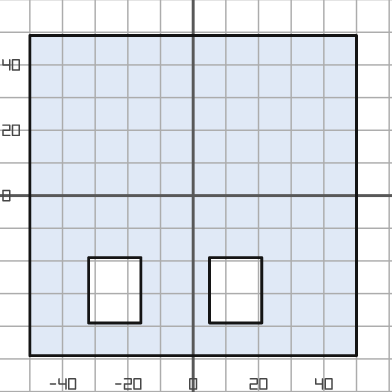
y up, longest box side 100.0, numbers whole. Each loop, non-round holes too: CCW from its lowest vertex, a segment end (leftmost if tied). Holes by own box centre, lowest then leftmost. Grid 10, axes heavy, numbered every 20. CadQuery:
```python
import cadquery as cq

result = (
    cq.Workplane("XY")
    .moveTo(-50.0, -49.0)
    .lineTo(50.0, -49.0)
    .lineTo(50.0, 49.0)
    .lineTo(-50.0, 49.0)
    .close()
    .moveTo(-32.0, -39.0)
    .lineTo(-16.0, -39.0)
    .lineTo(-16.0, -19.0)
    .lineTo(-32.0, -19.0)
    .close()
    .moveTo(5.0, -39.0)
    .lineTo(21.0, -39.0)
    .lineTo(21.0, -19.0)
    .lineTo(5.0, -19.0)
    .close()
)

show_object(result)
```